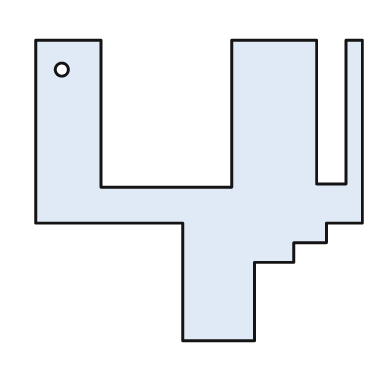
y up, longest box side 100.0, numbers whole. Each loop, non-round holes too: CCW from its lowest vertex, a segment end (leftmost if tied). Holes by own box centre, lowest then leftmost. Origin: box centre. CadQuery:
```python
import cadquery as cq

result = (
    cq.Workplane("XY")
    .moveTo(-5.0, -46.0)
    .lineTo(17.0, -46.0)
    .lineTo(17.0, -22.0)
    .lineTo(29.0, -22.0)
    .lineTo(29.0, -16.0)
    .lineTo(39.0, -16.0)
    .lineTo(39.0, -10.0)
    .lineTo(50.0, -10.0)
    .lineTo(50.0, 46.0)
    .lineTo(45.0, 46.0)
    .lineTo(45.0, 2.0)
    .lineTo(36.0, 2.0)
    .lineTo(36.0, 46.0)
    .lineTo(10.0, 46.0)
    .lineTo(10.0, 1.0)
    .lineTo(-30.0, 1.0)
    .lineTo(-30.0, 46.0)
    .lineTo(-50.0, 46.0)
    .lineTo(-50.0, -10.0)
    .lineTo(-5.0, -10.0)
    .close()
    .moveTo(-42.0, 37.0)
    .circle(2.0)
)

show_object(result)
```